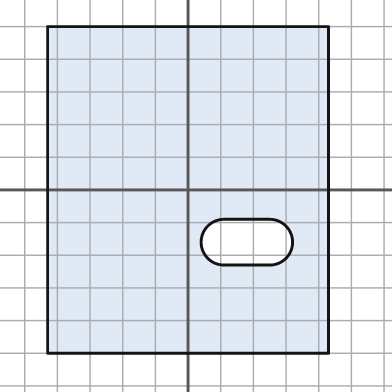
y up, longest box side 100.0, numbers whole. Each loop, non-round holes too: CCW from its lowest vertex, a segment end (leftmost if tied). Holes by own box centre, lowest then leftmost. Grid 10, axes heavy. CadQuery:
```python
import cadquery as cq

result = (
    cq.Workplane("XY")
    .moveTo(-43.0, -50.0)
    .lineTo(43.0, -50.0)
    .lineTo(43.0, 50.0)
    .lineTo(-43.0, 50.0)
    .close()
    .moveTo(11.0, -23.0)
    .lineTo(25.0, -23.0)
    .threePointArc((32.0, -16.0), (25.0, -9.0))
    .lineTo(11.0, -9.0)
    .threePointArc((4.0, -16.0), (11.0, -23.0))
    .close()
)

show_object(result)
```